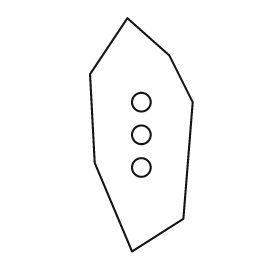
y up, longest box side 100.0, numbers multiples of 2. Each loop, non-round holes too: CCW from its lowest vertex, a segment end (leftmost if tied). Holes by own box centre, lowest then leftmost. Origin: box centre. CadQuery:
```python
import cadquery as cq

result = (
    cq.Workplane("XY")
    .moveTo(-4.0, -50.0)
    .lineTo(18.0, -36.0)
    .lineTo(22.0, 14.0)
    .lineTo(12.0, 34.0)
    .lineTo(-6.0, 50.0)
    .lineTo(-22.0, 26.0)
    .lineTo(-20.0, -12.0)
    .close()
    .moveTo(0.0, -14.0)
    .circle(4.0)
    .moveTo(0.0, 0.0)
    .circle(4.0)
    .moveTo(0.0, 14.0)
    .circle(4.0)
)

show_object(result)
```